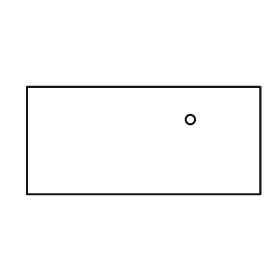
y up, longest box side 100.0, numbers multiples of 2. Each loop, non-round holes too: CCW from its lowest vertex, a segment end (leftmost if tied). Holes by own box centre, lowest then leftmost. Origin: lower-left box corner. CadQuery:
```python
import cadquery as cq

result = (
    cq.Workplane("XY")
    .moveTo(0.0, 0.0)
    .lineTo(100.0, 0.0)
    .lineTo(100.0, 46.0)
    .lineTo(0.0, 46.0)
    .close()
    .moveTo(70.0, 32.0)
    .circle(2.0)
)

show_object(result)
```